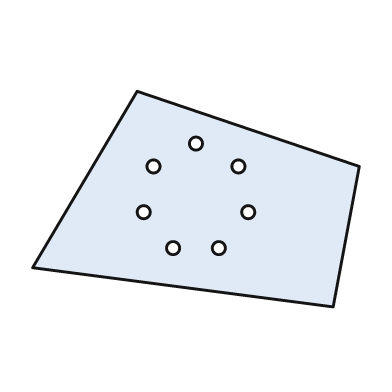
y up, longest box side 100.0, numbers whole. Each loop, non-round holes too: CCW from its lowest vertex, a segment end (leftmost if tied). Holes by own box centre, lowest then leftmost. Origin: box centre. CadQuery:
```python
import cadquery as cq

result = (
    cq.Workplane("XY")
    .moveTo(42.0, -33.0)
    .lineTo(50.0, 10.0)
    .lineTo(-18.0, 33.0)
    .lineTo(-50.0, -21.0)
    .close()
    .moveTo(-7.0, -15.0)
    .circle(2.0)
    .moveTo(7.0, -15.0)
    .circle(2.0)
    .moveTo(-16.0, -4.0)
    .circle(2.0)
    .moveTo(16.0, -4.0)
    .circle(2.0)
    .moveTo(-13.0, 10.0)
    .circle(2.0)
    .moveTo(13.0, 10.0)
    .circle(2.0)
    .moveTo(0.0, 17.0)
    .circle(2.0)
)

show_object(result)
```